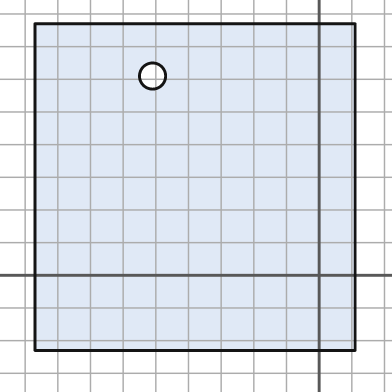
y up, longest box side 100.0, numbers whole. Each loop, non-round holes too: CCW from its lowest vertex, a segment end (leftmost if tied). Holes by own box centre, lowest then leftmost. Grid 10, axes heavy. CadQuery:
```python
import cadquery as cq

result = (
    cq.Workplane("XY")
    .moveTo(-87.0, -23.0)
    .lineTo(11.0, -23.0)
    .lineTo(11.0, 77.0)
    .lineTo(-87.0, 77.0)
    .close()
    .moveTo(-51.0, 61.0)
    .circle(4.0)
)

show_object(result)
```